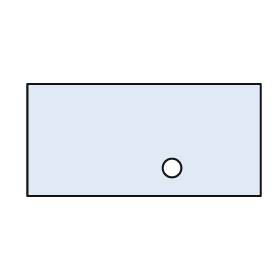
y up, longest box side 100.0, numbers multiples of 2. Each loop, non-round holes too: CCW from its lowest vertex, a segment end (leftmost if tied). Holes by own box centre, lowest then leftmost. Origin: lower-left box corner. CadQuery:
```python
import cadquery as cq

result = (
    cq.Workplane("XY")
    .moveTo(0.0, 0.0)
    .lineTo(100.0, 0.0)
    .lineTo(100.0, 48.0)
    .lineTo(0.0, 48.0)
    .close()
    .moveTo(62.0, 12.0)
    .circle(4.0)
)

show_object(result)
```